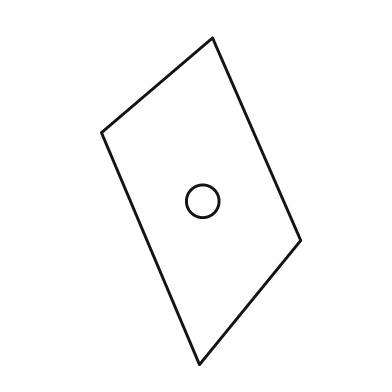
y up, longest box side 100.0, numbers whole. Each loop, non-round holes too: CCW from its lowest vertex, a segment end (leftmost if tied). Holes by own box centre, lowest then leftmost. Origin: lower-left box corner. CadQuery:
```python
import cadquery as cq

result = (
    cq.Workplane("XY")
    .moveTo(30.0, 0.0)
    .lineTo(61.0, 38.0)
    .lineTo(34.0, 100.0)
    .lineTo(0.0, 71.0)
    .close()
    .moveTo(31.0, 50.0)
    .circle(5.0)
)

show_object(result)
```